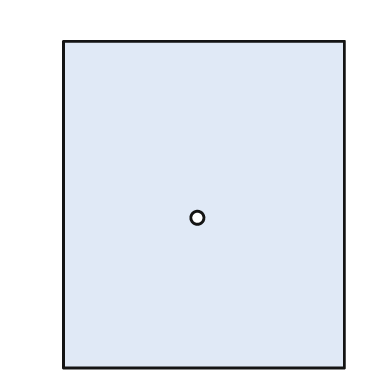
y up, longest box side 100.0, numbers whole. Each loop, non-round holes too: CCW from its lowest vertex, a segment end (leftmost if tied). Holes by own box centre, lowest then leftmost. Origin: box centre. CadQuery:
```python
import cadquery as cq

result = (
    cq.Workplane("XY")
    .moveTo(-43.0, -50.0)
    .lineTo(43.0, -50.0)
    .lineTo(43.0, 50.0)
    .lineTo(-43.0, 50.0)
    .close()
    .moveTo(-2.0, -4.0)
    .circle(2.0)
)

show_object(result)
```